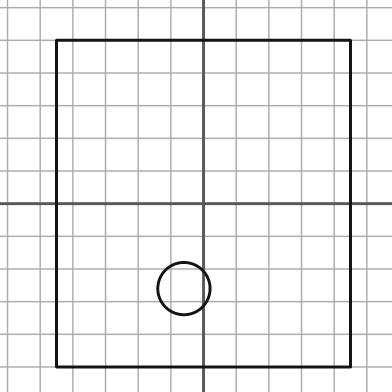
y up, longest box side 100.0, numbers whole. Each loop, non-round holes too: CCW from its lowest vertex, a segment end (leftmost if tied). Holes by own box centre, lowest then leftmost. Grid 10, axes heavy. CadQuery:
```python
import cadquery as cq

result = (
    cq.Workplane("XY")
    .moveTo(-45.0, -50.0)
    .lineTo(45.0, -50.0)
    .lineTo(45.0, 50.0)
    .lineTo(-45.0, 50.0)
    .close()
    .moveTo(-6.0, -26.0)
    .circle(8.0)
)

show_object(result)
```